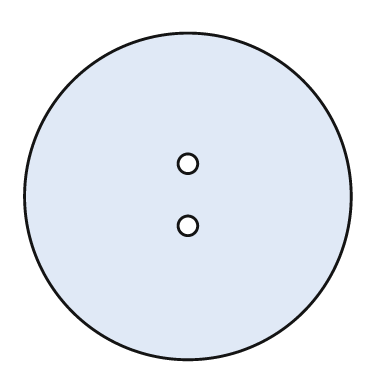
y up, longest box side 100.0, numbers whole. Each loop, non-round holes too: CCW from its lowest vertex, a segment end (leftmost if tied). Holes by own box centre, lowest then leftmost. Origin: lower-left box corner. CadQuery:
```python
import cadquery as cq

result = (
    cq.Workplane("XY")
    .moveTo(50.0, 50.0)
    .circle(50.0)
    .moveTo(50.0, 41.0)
    .circle(3.0)
    .moveTo(50.0, 60.0)
    .circle(3.0)
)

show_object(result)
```